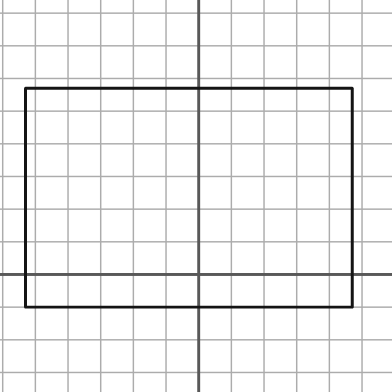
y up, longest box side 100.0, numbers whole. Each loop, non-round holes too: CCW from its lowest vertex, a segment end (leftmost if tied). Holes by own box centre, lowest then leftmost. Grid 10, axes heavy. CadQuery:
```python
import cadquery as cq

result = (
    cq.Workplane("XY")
    .moveTo(-53.0, -10.0)
    .lineTo(47.0, -10.0)
    .lineTo(47.0, 57.0)
    .lineTo(-53.0, 57.0)
    .close()
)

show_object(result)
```